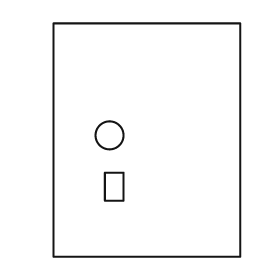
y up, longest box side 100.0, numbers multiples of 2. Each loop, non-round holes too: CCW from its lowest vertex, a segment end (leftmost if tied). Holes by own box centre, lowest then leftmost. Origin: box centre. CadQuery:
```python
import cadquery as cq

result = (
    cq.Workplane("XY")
    .moveTo(-40.0, -50.0)
    .lineTo(40.0, -50.0)
    .lineTo(40.0, 50.0)
    .lineTo(-40.0, 50.0)
    .close()
    .moveTo(-18.0, -26.0)
    .lineTo(-10.0, -26.0)
    .lineTo(-10.0, -14.0)
    .lineTo(-18.0, -14.0)
    .close()
    .moveTo(-16.0, 2.0)
    .circle(6.0)
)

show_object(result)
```